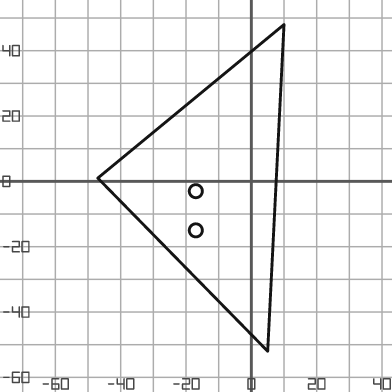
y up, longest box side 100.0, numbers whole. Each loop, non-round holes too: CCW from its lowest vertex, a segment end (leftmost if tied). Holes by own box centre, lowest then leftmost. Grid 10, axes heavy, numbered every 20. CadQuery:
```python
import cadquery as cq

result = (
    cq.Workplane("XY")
    .moveTo(5.0, -52.0)
    .lineTo(10.0, 48.0)
    .lineTo(-47.0, 1.0)
    .close()
    .moveTo(-17.0, -15.0)
    .circle(2.0)
    .moveTo(-17.0, -3.0)
    .circle(2.0)
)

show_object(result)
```